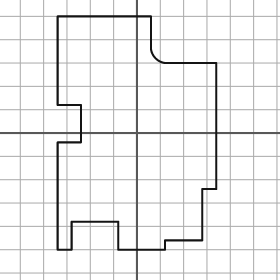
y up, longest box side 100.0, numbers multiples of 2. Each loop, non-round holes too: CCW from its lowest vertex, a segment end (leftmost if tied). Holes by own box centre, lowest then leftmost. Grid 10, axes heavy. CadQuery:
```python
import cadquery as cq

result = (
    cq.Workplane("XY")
    .moveTo(-34.0, -50.0)
    .lineTo(-28.0, -50.0)
    .lineTo(-28.0, -38.0)
    .lineTo(-8.0, -38.0)
    .lineTo(-8.0, -50.0)
    .lineTo(12.0, -50.0)
    .lineTo(12.0, -46.0)
    .lineTo(28.0, -46.0)
    .lineTo(28.0, -24.0)
    .lineTo(34.0, -24.0)
    .lineTo(34.0, 30.0)
    .lineTo(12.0, 30.0)
    .threePointArc((8.0, 32.0), (6.0, 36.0))
    .lineTo(6.0, 50.0)
    .lineTo(-34.0, 50.0)
    .lineTo(-34.0, 12.0)
    .lineTo(-24.0, 12.0)
    .lineTo(-24.0, -4.0)
    .lineTo(-34.0, -4.0)
    .close()
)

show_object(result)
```